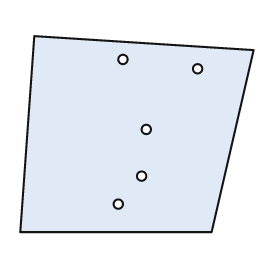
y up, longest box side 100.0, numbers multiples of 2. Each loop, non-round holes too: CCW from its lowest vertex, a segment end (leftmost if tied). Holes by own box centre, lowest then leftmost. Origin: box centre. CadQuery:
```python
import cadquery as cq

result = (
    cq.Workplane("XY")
    .moveTo(-50.0, -42.0)
    .lineTo(32.0, -42.0)
    .lineTo(50.0, 36.0)
    .lineTo(-44.0, 42.0)
    .close()
    .moveTo(-8.0, -30.0)
    .circle(2.0)
    .moveTo(2.0, -18.0)
    .circle(2.0)
    .moveTo(4.0, 2.0)
    .circle(2.0)
    .moveTo(26.0, 28.0)
    .circle(2.0)
    .moveTo(-6.0, 32.0)
    .circle(2.0)
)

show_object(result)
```